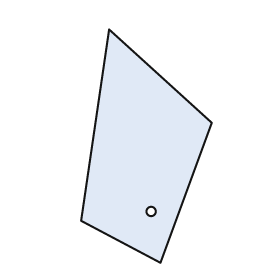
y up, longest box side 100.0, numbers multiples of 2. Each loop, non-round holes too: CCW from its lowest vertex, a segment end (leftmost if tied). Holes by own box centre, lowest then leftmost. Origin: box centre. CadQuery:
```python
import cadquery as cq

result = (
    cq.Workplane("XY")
    .moveTo(6.0, -50.0)
    .lineTo(28.0, 10.0)
    .lineTo(-16.0, 50.0)
    .lineTo(-28.0, -32.0)
    .close()
    .moveTo(2.0, -28.0)
    .circle(2.0)
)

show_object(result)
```